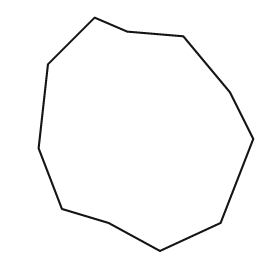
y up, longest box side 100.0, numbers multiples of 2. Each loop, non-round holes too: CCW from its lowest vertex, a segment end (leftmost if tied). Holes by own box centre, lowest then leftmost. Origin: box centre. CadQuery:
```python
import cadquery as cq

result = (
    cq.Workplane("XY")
    .moveTo(6.0, -50.0)
    .lineTo(32.0, -38.0)
    .lineTo(46.0, -2.0)
    .lineTo(36.0, 18.0)
    .lineTo(16.0, 42.0)
    .lineTo(-8.0, 44.0)
    .lineTo(-22.0, 50.0)
    .lineTo(-42.0, 30.0)
    .lineTo(-46.0, -6.0)
    .lineTo(-36.0, -32.0)
    .lineTo(-16.0, -38.0)
    .close()
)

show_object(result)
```